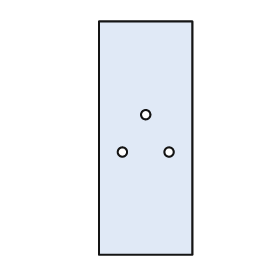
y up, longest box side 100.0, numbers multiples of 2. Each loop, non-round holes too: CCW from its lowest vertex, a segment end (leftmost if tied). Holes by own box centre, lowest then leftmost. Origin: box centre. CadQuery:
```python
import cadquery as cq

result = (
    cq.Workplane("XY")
    .moveTo(-20.0, -50.0)
    .lineTo(20.0, -50.0)
    .lineTo(20.0, 50.0)
    .lineTo(-20.0, 50.0)
    .close()
    .moveTo(-10.0, -6.0)
    .circle(2.0)
    .moveTo(10.0, -6.0)
    .circle(2.0)
    .moveTo(0.0, 10.0)
    .circle(2.0)
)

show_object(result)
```